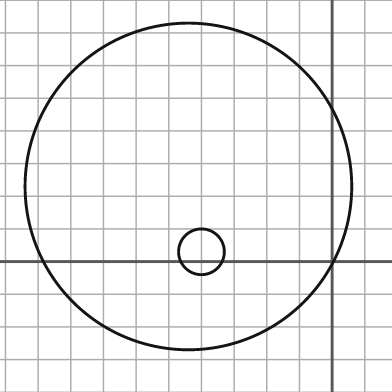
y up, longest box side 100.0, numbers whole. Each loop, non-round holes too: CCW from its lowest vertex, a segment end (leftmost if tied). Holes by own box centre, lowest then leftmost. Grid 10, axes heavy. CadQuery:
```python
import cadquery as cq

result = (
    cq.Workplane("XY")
    .moveTo(-44.0, 23.0)
    .circle(50.0)
    .moveTo(-40.0, 3.0)
    .circle(7.0)
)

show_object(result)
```